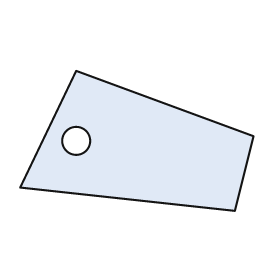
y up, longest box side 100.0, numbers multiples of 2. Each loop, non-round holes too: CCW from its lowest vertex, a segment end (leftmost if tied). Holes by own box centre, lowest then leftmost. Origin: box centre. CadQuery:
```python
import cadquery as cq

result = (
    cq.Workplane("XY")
    .moveTo(42.0, -30.0)
    .lineTo(50.0, 2.0)
    .lineTo(-26.0, 30.0)
    .lineTo(-50.0, -20.0)
    .close()
    .moveTo(-26.0, 0.0)
    .circle(6.0)
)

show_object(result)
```